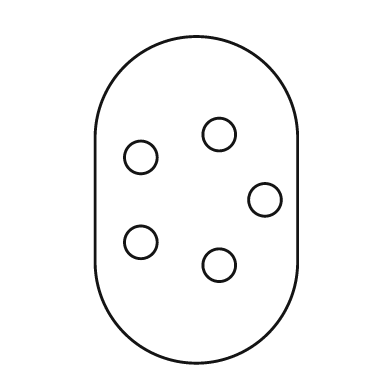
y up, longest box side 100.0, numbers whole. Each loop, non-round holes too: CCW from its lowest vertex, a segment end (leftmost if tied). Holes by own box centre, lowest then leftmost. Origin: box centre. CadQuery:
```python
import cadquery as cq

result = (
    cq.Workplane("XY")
    .moveTo(-31.0, -19.0)
    .threePointArc((0.0, -50.0), (31.0, -19.0))
    .lineTo(31.0, 19.0)
    .threePointArc((0.0, 50.0), (-31.0, 19.0))
    .close()
    .moveTo(7.0, -20.0)
    .circle(5.0)
    .moveTo(-17.0, -13.0)
    .circle(5.0)
    .moveTo(21.0, 0.0)
    .circle(5.0)
    .moveTo(-17.0, 13.0)
    .circle(5.0)
    .moveTo(7.0, 20.0)
    .circle(5.0)
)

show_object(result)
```